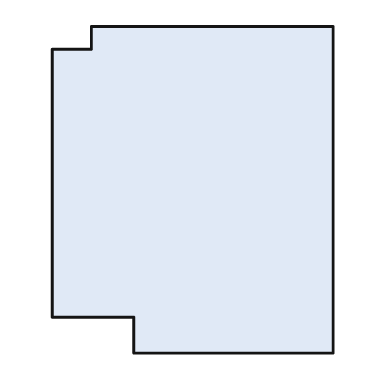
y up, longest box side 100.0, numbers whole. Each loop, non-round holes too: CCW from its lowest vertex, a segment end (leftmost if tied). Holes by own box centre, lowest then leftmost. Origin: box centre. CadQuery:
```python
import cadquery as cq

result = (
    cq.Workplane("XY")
    .moveTo(-18.0, -50.0)
    .lineTo(43.0, -50.0)
    .lineTo(43.0, 50.0)
    .lineTo(-31.0, 50.0)
    .lineTo(-31.0, 43.0)
    .lineTo(-43.0, 43.0)
    .lineTo(-43.0, -39.0)
    .lineTo(-18.0, -39.0)
    .close()
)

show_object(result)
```